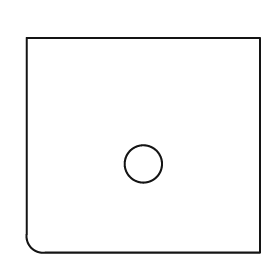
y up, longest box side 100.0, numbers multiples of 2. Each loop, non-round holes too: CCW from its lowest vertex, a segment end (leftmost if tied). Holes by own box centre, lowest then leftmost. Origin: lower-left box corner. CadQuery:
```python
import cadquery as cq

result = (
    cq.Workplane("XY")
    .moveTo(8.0, 0.0)
    .lineTo(100.0, 0.0)
    .lineTo(100.0, 92.0)
    .lineTo(0.0, 92.0)
    .lineTo(0.0, 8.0)
    .threePointArc((2.0, 2.0), (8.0, 0.0))
    .close()
    .moveTo(50.0, 38.0)
    .circle(8.0)
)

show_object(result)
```